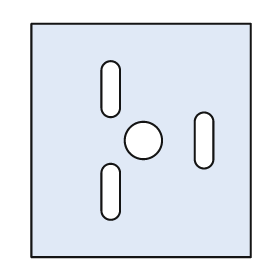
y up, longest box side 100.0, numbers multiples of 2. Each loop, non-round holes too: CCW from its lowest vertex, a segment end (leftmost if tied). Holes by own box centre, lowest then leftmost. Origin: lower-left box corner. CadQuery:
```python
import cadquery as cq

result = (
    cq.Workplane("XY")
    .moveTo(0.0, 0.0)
    .lineTo(94.0, 0.0)
    .lineTo(94.0, 100.0)
    .lineTo(0.0, 100.0)
    .close()
    .moveTo(30.0, 20.0)
    .threePointArc((34.0, 16.0), (38.0, 20.0))
    .lineTo(38.0, 36.0)
    .threePointArc((34.0, 40.0), (30.0, 36.0))
    .close()
    .moveTo(48.0, 50.0)
    .circle(8.0)
    .moveTo(70.0, 42.0)
    .threePointArc((74.0, 38.0), (78.0, 42.0))
    .lineTo(78.0, 58.0)
    .threePointArc((74.0, 62.0), (70.0, 58.0))
    .close()
    .moveTo(30.0, 64.0)
    .threePointArc((34.0, 60.0), (38.0, 64.0))
    .lineTo(38.0, 80.0)
    .threePointArc((34.0, 84.0), (30.0, 80.0))
    .close()
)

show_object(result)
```